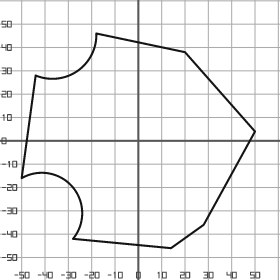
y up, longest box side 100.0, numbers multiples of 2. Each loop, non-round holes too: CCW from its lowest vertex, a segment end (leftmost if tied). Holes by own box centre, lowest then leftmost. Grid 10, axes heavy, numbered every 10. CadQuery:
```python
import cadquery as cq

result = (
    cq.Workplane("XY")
    .moveTo(14.0, -46.0)
    .lineTo(28.0, -36.0)
    .lineTo(50.0, 4.0)
    .lineTo(20.0, 38.0)
    .lineTo(-18.0, 46.0)
    .threePointArc((-26.0, 30.0), (-44.0, 28.0))
    .lineTo(-50.0, -16.0)
    .threePointArc((-28.0, -20.0), (-28.0, -42.0))
    .close()
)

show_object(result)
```